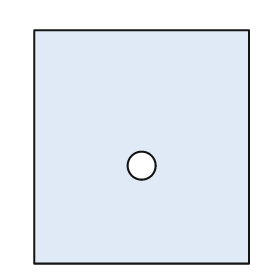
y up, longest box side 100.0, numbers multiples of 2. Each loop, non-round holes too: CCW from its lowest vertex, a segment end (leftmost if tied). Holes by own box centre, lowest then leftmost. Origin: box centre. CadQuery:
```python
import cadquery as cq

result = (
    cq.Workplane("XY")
    .moveTo(-46.0, -50.0)
    .lineTo(46.0, -50.0)
    .lineTo(46.0, 50.0)
    .lineTo(-46.0, 50.0)
    .close()
    .moveTo(0.0, -8.0)
    .circle(6.0)
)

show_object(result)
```